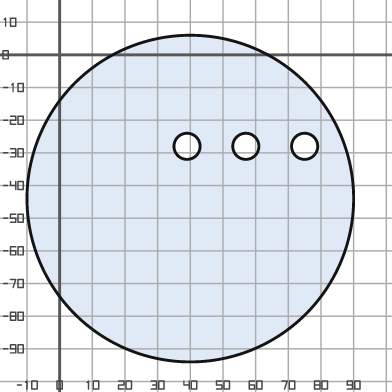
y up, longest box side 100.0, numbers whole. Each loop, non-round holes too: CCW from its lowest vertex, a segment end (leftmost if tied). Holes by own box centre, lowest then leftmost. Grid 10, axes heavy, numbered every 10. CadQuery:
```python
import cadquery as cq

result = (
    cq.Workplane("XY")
    .moveTo(40.0, -44.0)
    .circle(50.0)
    .moveTo(39.0, -28.0)
    .circle(4.0)
    .moveTo(57.0, -28.0)
    .circle(4.0)
    .moveTo(75.0, -28.0)
    .circle(4.0)
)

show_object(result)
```